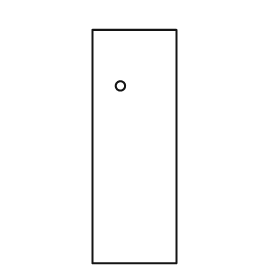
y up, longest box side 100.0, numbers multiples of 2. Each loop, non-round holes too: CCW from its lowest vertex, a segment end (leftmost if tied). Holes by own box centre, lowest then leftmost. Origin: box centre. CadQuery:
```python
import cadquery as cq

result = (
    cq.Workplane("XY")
    .moveTo(-18.0, -50.0)
    .lineTo(18.0, -50.0)
    .lineTo(18.0, 50.0)
    .lineTo(-18.0, 50.0)
    .close()
    .moveTo(-6.0, 26.0)
    .circle(2.0)
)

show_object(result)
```